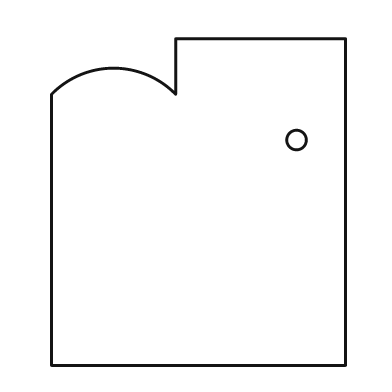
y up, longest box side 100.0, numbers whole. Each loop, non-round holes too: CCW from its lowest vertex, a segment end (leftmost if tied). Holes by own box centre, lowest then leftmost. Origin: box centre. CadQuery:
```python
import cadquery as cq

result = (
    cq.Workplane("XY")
    .moveTo(-45.0, -50.0)
    .lineTo(45.0, -50.0)
    .lineTo(45.0, 50.0)
    .lineTo(-7.0, 50.0)
    .lineTo(-7.0, 33.0)
    .threePointArc((-26.0, 41.0), (-45.0, 33.0))
    .close()
    .moveTo(30.0, 19.0)
    .circle(3.0)
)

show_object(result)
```